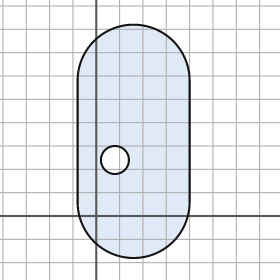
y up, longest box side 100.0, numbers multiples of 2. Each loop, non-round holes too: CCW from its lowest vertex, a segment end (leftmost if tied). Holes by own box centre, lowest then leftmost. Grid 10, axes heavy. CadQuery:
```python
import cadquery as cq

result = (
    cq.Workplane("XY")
    .moveTo(-8.0, 6.0)
    .threePointArc((16.0, -18.0), (40.0, 6.0))
    .lineTo(40.0, 58.0)
    .threePointArc((16.0, 82.0), (-8.0, 58.0))
    .close()
    .moveTo(8.0, 24.0)
    .circle(6.0)
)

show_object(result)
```